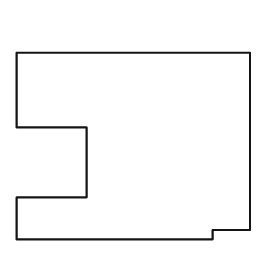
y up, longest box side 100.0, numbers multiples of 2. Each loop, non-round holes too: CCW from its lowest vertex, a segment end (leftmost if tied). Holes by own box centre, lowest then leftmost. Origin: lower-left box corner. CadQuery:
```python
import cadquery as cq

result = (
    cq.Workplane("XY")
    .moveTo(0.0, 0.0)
    .lineTo(84.0, 0.0)
    .lineTo(84.0, 4.0)
    .lineTo(100.0, 4.0)
    .lineTo(100.0, 80.0)
    .lineTo(0.0, 80.0)
    .lineTo(0.0, 48.0)
    .lineTo(30.0, 48.0)
    .lineTo(30.0, 18.0)
    .lineTo(0.0, 18.0)
    .close()
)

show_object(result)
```